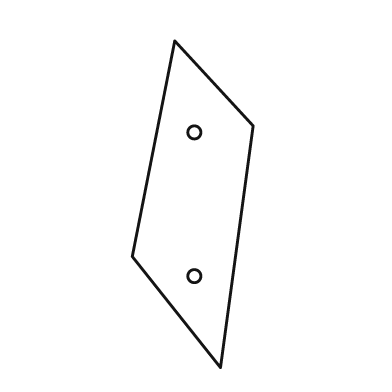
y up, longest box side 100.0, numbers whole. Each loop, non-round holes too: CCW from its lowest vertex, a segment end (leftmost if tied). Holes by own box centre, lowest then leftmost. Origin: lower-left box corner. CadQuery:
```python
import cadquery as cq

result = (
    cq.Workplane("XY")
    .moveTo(27.0, 0.0)
    .lineTo(37.0, 74.0)
    .lineTo(13.0, 100.0)
    .lineTo(0.0, 34.0)
    .close()
    .moveTo(19.0, 28.0)
    .circle(2.0)
    .moveTo(19.0, 72.0)
    .circle(2.0)
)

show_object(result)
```